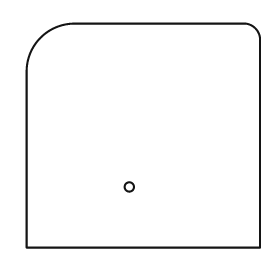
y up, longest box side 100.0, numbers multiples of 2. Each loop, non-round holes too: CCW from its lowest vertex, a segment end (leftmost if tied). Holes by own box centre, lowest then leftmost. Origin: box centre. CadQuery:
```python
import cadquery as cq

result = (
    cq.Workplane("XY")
    .moveTo(-50.0, -48.0)
    .lineTo(50.0, -48.0)
    .lineTo(50.0, 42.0)
    .threePointArc((48.0, 46.0), (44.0, 48.0))
    .lineTo(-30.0, 48.0)
    .threePointArc((-44.0, 42.0), (-50.0, 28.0))
    .close()
    .moveTo(-6.0, -22.0)
    .circle(2.0)
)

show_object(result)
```